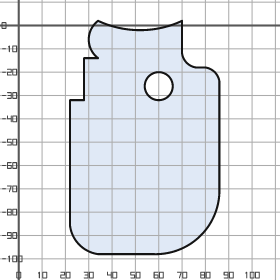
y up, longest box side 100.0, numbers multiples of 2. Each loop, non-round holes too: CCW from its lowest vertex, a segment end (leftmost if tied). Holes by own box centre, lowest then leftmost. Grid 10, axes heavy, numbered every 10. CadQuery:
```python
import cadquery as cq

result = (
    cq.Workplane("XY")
    .moveTo(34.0, -98.0)
    .lineTo(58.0, -98.0)
    .threePointArc((78.0, -90.0), (86.0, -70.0))
    .lineTo(86.0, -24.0)
    .threePointArc((84.0, -20.0), (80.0, -18.0))
    .lineTo(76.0, -18.0)
    .threePointArc((72.0, -16.0), (70.0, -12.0))
    .lineTo(70.0, 2.0)
    .threePointArc((52.0, -2.0), (34.0, 2.0))
    .threePointArc((30.0, -6.0), (34.0, -14.0))
    .lineTo(28.0, -14.0)
    .lineTo(28.0, -32.0)
    .lineTo(22.0, -32.0)
    .lineTo(22.0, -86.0)
    .threePointArc((26.0, -94.0), (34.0, -98.0))
    .close()
    .moveTo(60.0, -26.0)
    .circle(6.0)
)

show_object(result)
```